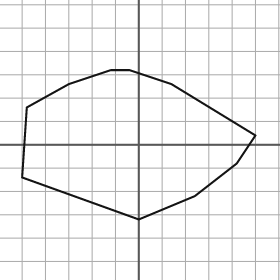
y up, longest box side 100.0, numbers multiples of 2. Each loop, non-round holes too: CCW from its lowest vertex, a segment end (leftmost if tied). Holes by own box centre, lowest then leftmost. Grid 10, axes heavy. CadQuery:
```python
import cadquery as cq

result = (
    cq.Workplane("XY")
    .moveTo(0.0, -32.0)
    .lineTo(24.0, -22.0)
    .lineTo(42.0, -8.0)
    .lineTo(50.0, 4.0)
    .lineTo(14.0, 26.0)
    .lineTo(-4.0, 32.0)
    .lineTo(-12.0, 32.0)
    .lineTo(-30.0, 26.0)
    .lineTo(-48.0, 16.0)
    .lineTo(-50.0, -14.0)
    .close()
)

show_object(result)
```